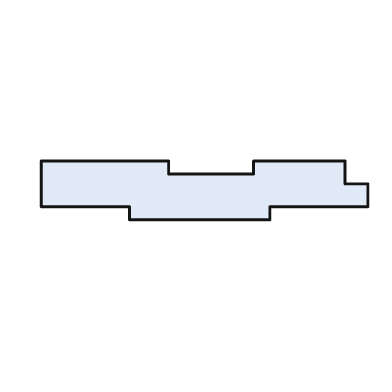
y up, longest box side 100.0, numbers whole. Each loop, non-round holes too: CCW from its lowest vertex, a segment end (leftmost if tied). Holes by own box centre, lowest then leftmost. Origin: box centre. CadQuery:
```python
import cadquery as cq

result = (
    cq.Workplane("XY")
    .moveTo(-23.0, -9.0)
    .lineTo(20.0, -9.0)
    .lineTo(20.0, -5.0)
    .lineTo(50.0, -5.0)
    .lineTo(50.0, 2.0)
    .lineTo(43.0, 2.0)
    .lineTo(43.0, 9.0)
    .lineTo(15.0, 9.0)
    .lineTo(15.0, 5.0)
    .lineTo(-11.0, 5.0)
    .lineTo(-11.0, 9.0)
    .lineTo(-50.0, 9.0)
    .lineTo(-50.0, -5.0)
    .lineTo(-23.0, -5.0)
    .close()
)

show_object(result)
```